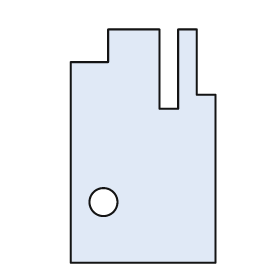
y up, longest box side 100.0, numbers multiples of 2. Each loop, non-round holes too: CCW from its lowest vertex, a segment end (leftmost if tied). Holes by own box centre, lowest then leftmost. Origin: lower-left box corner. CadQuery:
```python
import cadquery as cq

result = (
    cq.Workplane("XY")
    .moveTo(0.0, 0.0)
    .lineTo(62.0, 0.0)
    .lineTo(62.0, 72.0)
    .lineTo(54.0, 72.0)
    .lineTo(54.0, 100.0)
    .lineTo(46.0, 100.0)
    .lineTo(46.0, 66.0)
    .lineTo(38.0, 66.0)
    .lineTo(38.0, 100.0)
    .lineTo(16.0, 100.0)
    .lineTo(16.0, 86.0)
    .lineTo(0.0, 86.0)
    .close()
    .moveTo(14.0, 26.0)
    .circle(6.0)
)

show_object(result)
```